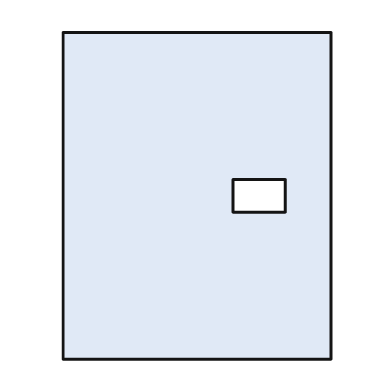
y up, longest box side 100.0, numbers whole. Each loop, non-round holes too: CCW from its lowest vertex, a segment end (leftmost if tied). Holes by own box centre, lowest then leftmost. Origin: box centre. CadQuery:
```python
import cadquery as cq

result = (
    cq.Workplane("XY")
    .moveTo(-41.0, -50.0)
    .lineTo(41.0, -50.0)
    .lineTo(41.0, 50.0)
    .lineTo(-41.0, 50.0)
    .close()
    .moveTo(11.0, -5.0)
    .lineTo(27.0, -5.0)
    .lineTo(27.0, 5.0)
    .lineTo(11.0, 5.0)
    .close()
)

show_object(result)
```